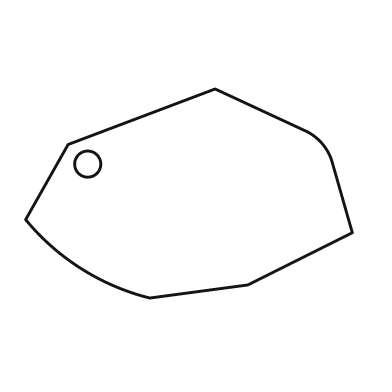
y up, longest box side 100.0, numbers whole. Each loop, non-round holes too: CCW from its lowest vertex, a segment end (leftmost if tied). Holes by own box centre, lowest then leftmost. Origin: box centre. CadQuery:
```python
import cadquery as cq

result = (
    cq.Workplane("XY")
    .moveTo(-12.0, -32.0)
    .lineTo(18.0, -28.0)
    .lineTo(50.0, -12.0)
    .lineTo(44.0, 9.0)
    .threePointArc((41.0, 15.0), (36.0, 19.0))
    .lineTo(8.0, 32.0)
    .lineTo(-37.0, 15.0)
    .lineTo(-50.0, -8.0)
    .threePointArc((-33.0, -23.0), (-12.0, -32.0))
    .close()
    .moveTo(-31.0, 9.0)
    .circle(4.0)
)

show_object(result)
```